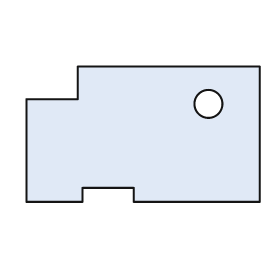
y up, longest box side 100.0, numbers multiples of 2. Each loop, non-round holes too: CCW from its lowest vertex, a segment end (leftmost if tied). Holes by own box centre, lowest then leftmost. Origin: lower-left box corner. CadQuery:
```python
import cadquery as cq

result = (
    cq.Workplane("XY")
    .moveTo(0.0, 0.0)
    .lineTo(24.0, 0.0)
    .lineTo(24.0, 6.0)
    .lineTo(46.0, 6.0)
    .lineTo(46.0, 0.0)
    .lineTo(100.0, 0.0)
    .lineTo(100.0, 58.0)
    .lineTo(22.0, 58.0)
    .lineTo(22.0, 44.0)
    .lineTo(0.0, 44.0)
    .close()
    .moveTo(78.0, 42.0)
    .circle(6.0)
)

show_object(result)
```